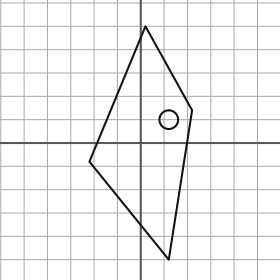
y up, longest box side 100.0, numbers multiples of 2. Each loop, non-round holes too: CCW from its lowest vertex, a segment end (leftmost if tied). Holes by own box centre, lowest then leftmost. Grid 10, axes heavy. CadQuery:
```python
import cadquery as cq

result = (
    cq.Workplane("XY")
    .moveTo(12.0, -50.0)
    .lineTo(22.0, 14.0)
    .lineTo(2.0, 50.0)
    .lineTo(-22.0, -8.0)
    .close()
    .moveTo(12.0, 10.0)
    .circle(4.0)
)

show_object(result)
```